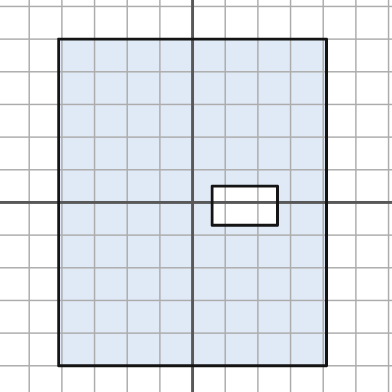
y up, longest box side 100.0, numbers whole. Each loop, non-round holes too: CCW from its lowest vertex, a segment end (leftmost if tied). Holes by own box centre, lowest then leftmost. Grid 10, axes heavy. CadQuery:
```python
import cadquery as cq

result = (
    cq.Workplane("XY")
    .moveTo(-41.0, -50.0)
    .lineTo(41.0, -50.0)
    .lineTo(41.0, 50.0)
    .lineTo(-41.0, 50.0)
    .close()
    .moveTo(6.0, -7.0)
    .lineTo(26.0, -7.0)
    .lineTo(26.0, 5.0)
    .lineTo(6.0, 5.0)
    .close()
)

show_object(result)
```